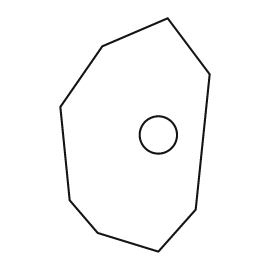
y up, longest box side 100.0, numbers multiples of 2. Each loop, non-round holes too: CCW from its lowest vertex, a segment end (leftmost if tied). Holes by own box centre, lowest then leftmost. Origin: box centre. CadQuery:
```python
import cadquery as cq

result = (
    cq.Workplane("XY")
    .moveTo(10.0, -50.0)
    .lineTo(26.0, -32.0)
    .lineTo(32.0, 26.0)
    .lineTo(14.0, 50.0)
    .lineTo(-14.0, 38.0)
    .lineTo(-32.0, 12.0)
    .lineTo(-28.0, -28.0)
    .lineTo(-16.0, -42.0)
    .close()
    .moveTo(10.0, 0.0)
    .circle(8.0)
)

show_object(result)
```